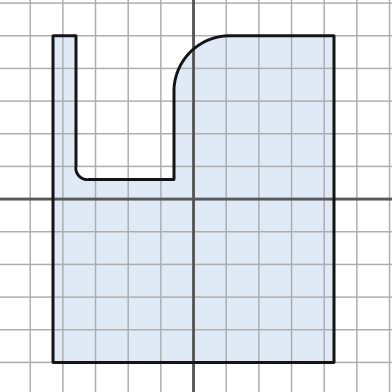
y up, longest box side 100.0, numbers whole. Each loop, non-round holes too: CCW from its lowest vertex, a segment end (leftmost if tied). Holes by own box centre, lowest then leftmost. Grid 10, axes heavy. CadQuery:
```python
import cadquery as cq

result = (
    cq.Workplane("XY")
    .moveTo(-43.0, -50.0)
    .lineTo(43.0, -50.0)
    .lineTo(43.0, 50.0)
    .lineTo(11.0, 50.0)
    .threePointArc((-1.0, 45.0), (-6.0, 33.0))
    .lineTo(-6.0, 6.0)
    .lineTo(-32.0, 6.0)
    .threePointArc((-35.0, 7.0), (-36.0, 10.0))
    .lineTo(-36.0, 50.0)
    .lineTo(-43.0, 50.0)
    .close()
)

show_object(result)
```